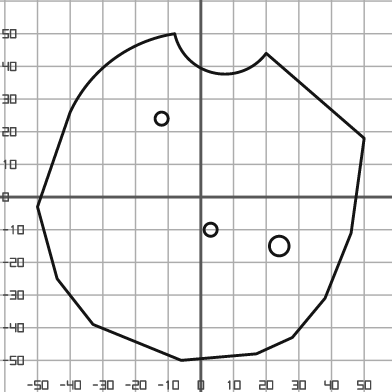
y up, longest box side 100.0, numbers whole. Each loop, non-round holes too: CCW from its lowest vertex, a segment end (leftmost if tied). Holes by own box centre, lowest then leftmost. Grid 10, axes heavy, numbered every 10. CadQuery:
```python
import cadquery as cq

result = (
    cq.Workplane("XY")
    .moveTo(-6.0, -50.0)
    .lineTo(17.0, -48.0)
    .lineTo(28.0, -43.0)
    .lineTo(38.0, -31.0)
    .lineTo(46.0, -11.0)
    .lineTo(50.0, 18.0)
    .lineTo(20.0, 44.0)
    .threePointArc((4.0, 38.0), (-8.0, 50.0))
    .threePointArc((-27.0, 42.0), (-40.0, 26.0))
    .lineTo(-50.0, -3.0)
    .lineTo(-44.0, -25.0)
    .lineTo(-33.0, -39.0)
    .close()
    .moveTo(24.0, -15.0)
    .circle(3.0)
    .moveTo(3.0, -10.0)
    .circle(2.0)
    .moveTo(-12.0, 24.0)
    .circle(2.0)
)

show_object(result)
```